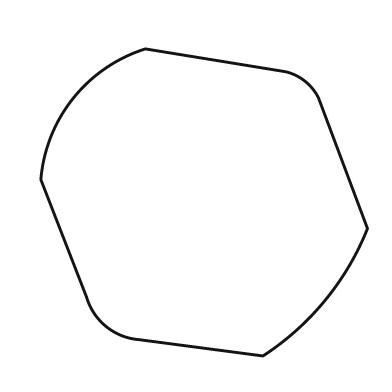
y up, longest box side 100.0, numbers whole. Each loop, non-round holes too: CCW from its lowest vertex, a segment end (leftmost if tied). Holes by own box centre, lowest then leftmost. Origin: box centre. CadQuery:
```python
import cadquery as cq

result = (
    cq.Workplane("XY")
    .moveTo(18.0, -47.0)
    .threePointArc((37.0, -30.0), (50.0, -8.0))
    .lineTo(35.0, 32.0)
    .threePointArc((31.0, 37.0), (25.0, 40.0))
    .lineTo(-18.0, 47.0)
    .threePointArc((-40.0, 32.0), (-50.0, 7.0))
    .lineTo(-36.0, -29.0)
    .threePointArc((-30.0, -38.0), (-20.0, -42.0))
    .close()
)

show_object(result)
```